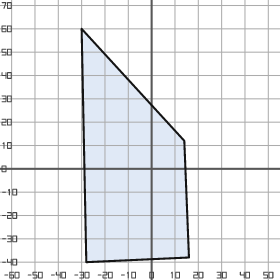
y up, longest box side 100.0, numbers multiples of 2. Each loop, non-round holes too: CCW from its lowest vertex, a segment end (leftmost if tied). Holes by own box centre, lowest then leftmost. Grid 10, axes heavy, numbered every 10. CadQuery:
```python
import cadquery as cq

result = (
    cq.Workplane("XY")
    .moveTo(-28.0, -40.0)
    .lineTo(16.0, -38.0)
    .lineTo(14.0, 12.0)
    .lineTo(-30.0, 60.0)
    .close()
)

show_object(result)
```